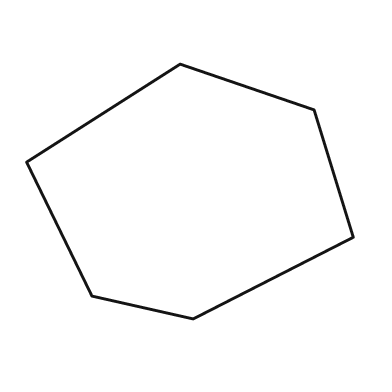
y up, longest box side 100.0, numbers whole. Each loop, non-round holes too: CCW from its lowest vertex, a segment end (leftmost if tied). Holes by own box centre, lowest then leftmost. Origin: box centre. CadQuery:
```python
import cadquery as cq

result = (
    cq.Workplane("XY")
    .moveTo(1.0, -39.0)
    .lineTo(50.0, -14.0)
    .lineTo(38.0, 25.0)
    .lineTo(-3.0, 39.0)
    .lineTo(-50.0, 9.0)
    .lineTo(-30.0, -32.0)
    .close()
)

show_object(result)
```